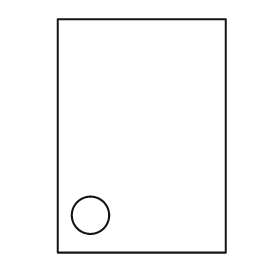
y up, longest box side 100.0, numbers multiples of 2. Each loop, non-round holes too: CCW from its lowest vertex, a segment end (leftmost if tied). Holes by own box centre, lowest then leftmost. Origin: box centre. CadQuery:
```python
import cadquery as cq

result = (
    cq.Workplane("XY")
    .moveTo(-36.0, -50.0)
    .lineTo(36.0, -50.0)
    .lineTo(36.0, 50.0)
    .lineTo(-36.0, 50.0)
    .close()
    .moveTo(-22.0, -34.0)
    .circle(8.0)
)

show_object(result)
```